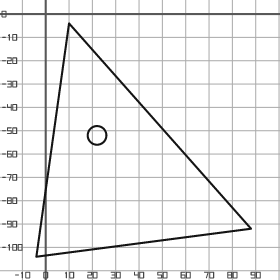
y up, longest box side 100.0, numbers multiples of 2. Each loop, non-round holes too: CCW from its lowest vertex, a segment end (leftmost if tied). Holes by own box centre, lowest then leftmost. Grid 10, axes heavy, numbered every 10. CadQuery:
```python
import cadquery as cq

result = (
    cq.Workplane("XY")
    .moveTo(-4.0, -104.0)
    .lineTo(88.0, -92.0)
    .lineTo(10.0, -4.0)
    .close()
    .moveTo(22.0, -52.0)
    .circle(4.0)
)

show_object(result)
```